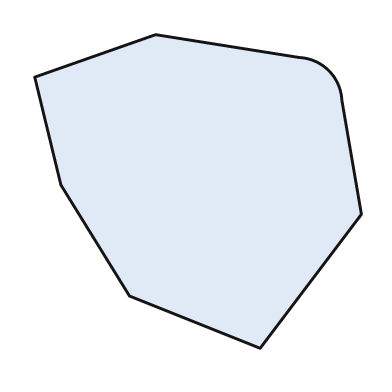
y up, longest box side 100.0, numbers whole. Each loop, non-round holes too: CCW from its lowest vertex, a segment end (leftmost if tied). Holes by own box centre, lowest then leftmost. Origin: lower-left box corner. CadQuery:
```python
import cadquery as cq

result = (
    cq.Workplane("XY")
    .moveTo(69.0, 0.0)
    .lineTo(100.0, 41.0)
    .lineTo(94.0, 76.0)
    .threePointArc((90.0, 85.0), (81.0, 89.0))
    .lineTo(37.0, 96.0)
    .lineTo(0.0, 83.0)
    .lineTo(8.0, 50.0)
    .lineTo(29.0, 16.0)
    .close()
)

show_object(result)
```